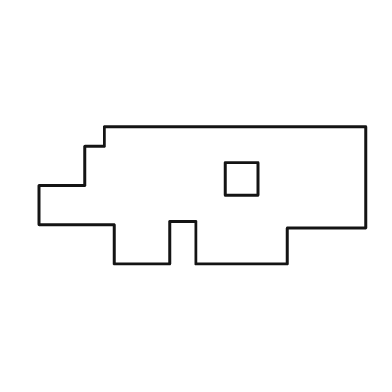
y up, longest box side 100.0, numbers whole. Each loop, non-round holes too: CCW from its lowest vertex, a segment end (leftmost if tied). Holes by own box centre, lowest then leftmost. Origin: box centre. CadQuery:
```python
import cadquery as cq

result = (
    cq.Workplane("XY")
    .moveTo(-27.0, -21.0)
    .lineTo(-10.0, -21.0)
    .lineTo(-10.0, -8.0)
    .lineTo(-2.0, -8.0)
    .lineTo(-2.0, -21.0)
    .lineTo(26.0, -21.0)
    .lineTo(26.0, -10.0)
    .lineTo(50.0, -10.0)
    .lineTo(50.0, 21.0)
    .lineTo(-30.0, 21.0)
    .lineTo(-30.0, 15.0)
    .lineTo(-36.0, 15.0)
    .lineTo(-36.0, 3.0)
    .lineTo(-50.0, 3.0)
    .lineTo(-50.0, -9.0)
    .lineTo(-27.0, -9.0)
    .close()
    .moveTo(7.0, 0.0)
    .lineTo(17.0, 0.0)
    .lineTo(17.0, 10.0)
    .lineTo(7.0, 10.0)
    .close()
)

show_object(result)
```